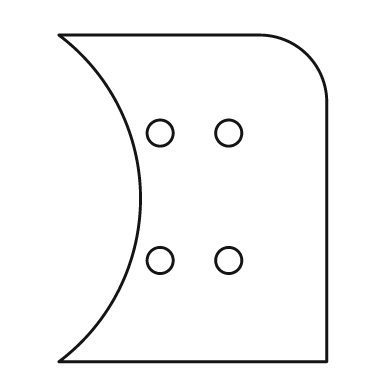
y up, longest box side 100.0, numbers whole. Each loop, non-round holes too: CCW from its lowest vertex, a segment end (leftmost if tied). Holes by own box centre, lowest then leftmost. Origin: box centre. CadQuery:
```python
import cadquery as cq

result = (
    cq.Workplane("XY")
    .moveTo(-41.0, -50.0)
    .lineTo(41.0, -50.0)
    .lineTo(41.0, 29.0)
    .threePointArc((35.0, 44.0), (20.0, 50.0))
    .lineTo(-41.0, 50.0)
    .threePointArc((-16.0, 0.0), (-41.0, -50.0))
    .close()
    .moveTo(-10.0, -19.0)
    .circle(4.0)
    .moveTo(11.0, -19.0)
    .circle(4.0)
    .moveTo(-10.0, 20.0)
    .circle(4.0)
    .moveTo(11.0, 20.0)
    .circle(4.0)
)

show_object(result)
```